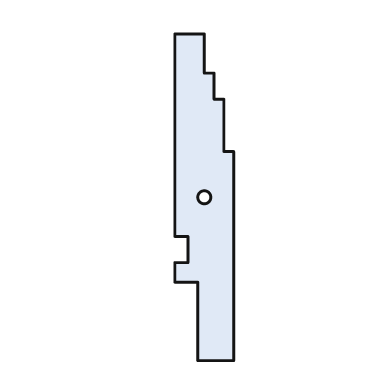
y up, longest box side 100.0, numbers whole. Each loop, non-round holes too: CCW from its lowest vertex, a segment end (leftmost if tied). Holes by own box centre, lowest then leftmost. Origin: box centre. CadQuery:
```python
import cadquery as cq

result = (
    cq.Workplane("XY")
    .moveTo(-2.0, -50.0)
    .lineTo(9.0, -50.0)
    .lineTo(9.0, 14.0)
    .lineTo(6.0, 14.0)
    .lineTo(6.0, 30.0)
    .lineTo(3.0, 30.0)
    .lineTo(3.0, 38.0)
    .lineTo(0.0, 38.0)
    .lineTo(0.0, 50.0)
    .lineTo(-9.0, 50.0)
    .lineTo(-9.0, -12.0)
    .lineTo(-5.0, -12.0)
    .lineTo(-5.0, -20.0)
    .lineTo(-9.0, -20.0)
    .lineTo(-9.0, -26.0)
    .lineTo(-2.0, -26.0)
    .close()
    .moveTo(0.0, 0.0)
    .circle(2.0)
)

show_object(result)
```